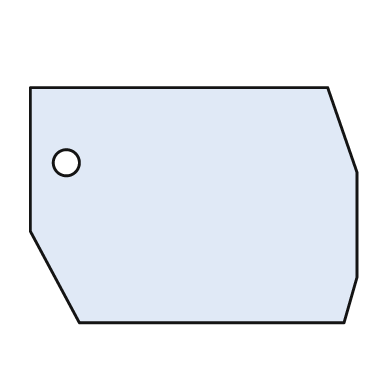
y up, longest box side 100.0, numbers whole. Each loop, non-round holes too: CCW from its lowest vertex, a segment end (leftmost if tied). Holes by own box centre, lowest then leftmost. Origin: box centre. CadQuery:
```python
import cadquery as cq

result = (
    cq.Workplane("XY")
    .moveTo(-35.0, -36.0)
    .lineTo(46.0, -36.0)
    .lineTo(50.0, -22.0)
    .lineTo(50.0, 10.0)
    .lineTo(41.0, 36.0)
    .lineTo(-50.0, 36.0)
    .lineTo(-50.0, -8.0)
    .close()
    .moveTo(-39.0, 13.0)
    .circle(4.0)
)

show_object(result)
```